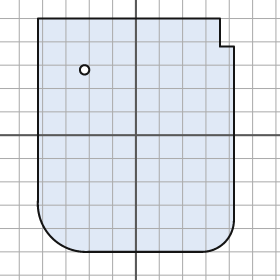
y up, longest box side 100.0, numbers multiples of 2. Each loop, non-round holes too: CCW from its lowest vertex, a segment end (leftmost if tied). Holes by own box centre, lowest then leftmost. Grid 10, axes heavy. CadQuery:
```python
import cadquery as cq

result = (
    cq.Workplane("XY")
    .moveTo(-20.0, -50.0)
    .lineTo(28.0, -50.0)
    .threePointArc((38.0, -46.0), (42.0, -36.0))
    .lineTo(42.0, 38.0)
    .lineTo(36.0, 38.0)
    .lineTo(36.0, 50.0)
    .lineTo(-42.0, 50.0)
    .lineTo(-42.0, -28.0)
    .threePointArc((-36.0, -44.0), (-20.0, -50.0))
    .close()
    .moveTo(-22.0, 28.0)
    .circle(2.0)
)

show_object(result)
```